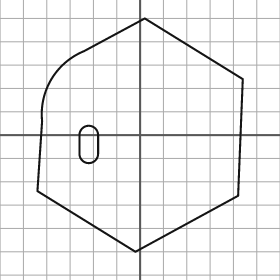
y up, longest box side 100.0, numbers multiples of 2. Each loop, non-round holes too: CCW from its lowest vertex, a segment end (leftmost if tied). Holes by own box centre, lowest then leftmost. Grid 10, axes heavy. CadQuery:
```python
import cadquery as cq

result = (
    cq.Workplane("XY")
    .moveTo(-2.0, -50.0)
    .lineTo(42.0, -26.0)
    .lineTo(44.0, 24.0)
    .lineTo(2.0, 50.0)
    .lineTo(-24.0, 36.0)
    .threePointArc((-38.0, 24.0), (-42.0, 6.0))
    .lineTo(-44.0, -24.0)
    .close()
    .moveTo(-26.0, -8.0)
    .threePointArc((-22.0, -12.0), (-18.0, -8.0))
    .lineTo(-18.0, 0.0)
    .threePointArc((-22.0, 4.0), (-26.0, 0.0))
    .close()
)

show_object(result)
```